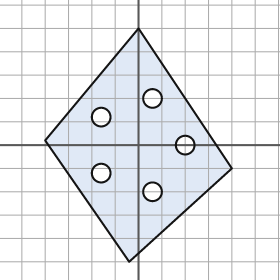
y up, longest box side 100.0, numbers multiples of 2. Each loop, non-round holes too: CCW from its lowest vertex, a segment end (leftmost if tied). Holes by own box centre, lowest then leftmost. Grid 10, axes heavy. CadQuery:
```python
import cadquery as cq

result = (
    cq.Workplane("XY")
    .moveTo(-4.0, -50.0)
    .lineTo(40.0, -10.0)
    .lineTo(0.0, 50.0)
    .lineTo(-40.0, 2.0)
    .close()
    .moveTo(6.0, -20.0)
    .circle(4.0)
    .moveTo(-16.0, -12.0)
    .circle(4.0)
    .moveTo(20.0, 0.0)
    .circle(4.0)
    .moveTo(-16.0, 12.0)
    .circle(4.0)
    .moveTo(6.0, 20.0)
    .circle(4.0)
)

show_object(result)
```